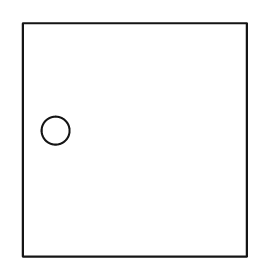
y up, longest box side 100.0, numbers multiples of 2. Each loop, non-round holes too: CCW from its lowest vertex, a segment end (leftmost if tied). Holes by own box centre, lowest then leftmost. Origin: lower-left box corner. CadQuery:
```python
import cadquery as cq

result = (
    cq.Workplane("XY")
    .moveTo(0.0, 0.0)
    .lineTo(96.0, 0.0)
    .lineTo(96.0, 100.0)
    .lineTo(0.0, 100.0)
    .close()
    .moveTo(14.0, 54.0)
    .circle(6.0)
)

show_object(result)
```